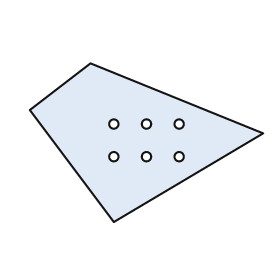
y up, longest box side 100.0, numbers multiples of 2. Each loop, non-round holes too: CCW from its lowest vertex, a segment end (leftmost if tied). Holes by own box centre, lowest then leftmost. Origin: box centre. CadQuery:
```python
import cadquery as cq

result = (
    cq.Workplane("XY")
    .moveTo(-14.0, -34.0)
    .lineTo(50.0, 4.0)
    .lineTo(-24.0, 34.0)
    .lineTo(-50.0, 14.0)
    .close()
    .moveTo(-14.0, -6.0)
    .circle(2.0)
    .moveTo(0.0, -6.0)
    .circle(2.0)
    .moveTo(14.0, -6.0)
    .circle(2.0)
    .moveTo(-14.0, 8.0)
    .circle(2.0)
    .moveTo(0.0, 8.0)
    .circle(2.0)
    .moveTo(14.0, 8.0)
    .circle(2.0)
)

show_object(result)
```